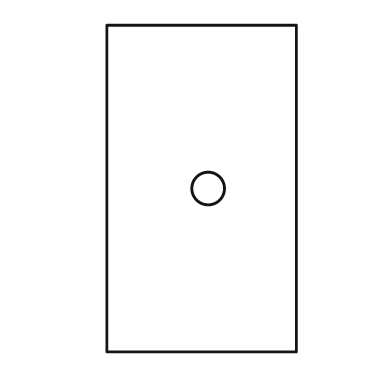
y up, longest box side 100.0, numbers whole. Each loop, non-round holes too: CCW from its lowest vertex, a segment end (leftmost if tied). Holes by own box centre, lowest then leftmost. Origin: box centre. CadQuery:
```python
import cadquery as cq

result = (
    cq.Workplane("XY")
    .moveTo(-29.0, -50.0)
    .lineTo(29.0, -50.0)
    .lineTo(29.0, 50.0)
    .lineTo(-29.0, 50.0)
    .close()
    .moveTo(2.0, 0.0)
    .circle(5.0)
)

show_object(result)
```